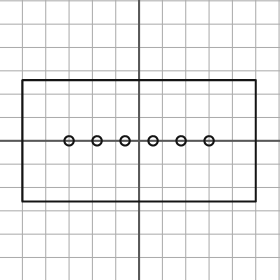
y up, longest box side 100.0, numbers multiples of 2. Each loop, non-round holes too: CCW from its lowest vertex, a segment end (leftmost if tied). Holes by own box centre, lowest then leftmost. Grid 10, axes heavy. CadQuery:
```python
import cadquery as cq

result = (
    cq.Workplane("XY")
    .moveTo(-50.0, -26.0)
    .lineTo(50.0, -26.0)
    .lineTo(50.0, 26.0)
    .lineTo(-50.0, 26.0)
    .close()
    .moveTo(-30.0, 0.0)
    .circle(2.0)
    .moveTo(-18.0, 0.0)
    .circle(2.0)
    .moveTo(-6.0, 0.0)
    .circle(2.0)
    .moveTo(6.0, 0.0)
    .circle(2.0)
    .moveTo(18.0, 0.0)
    .circle(2.0)
    .moveTo(30.0, 0.0)
    .circle(2.0)
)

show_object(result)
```